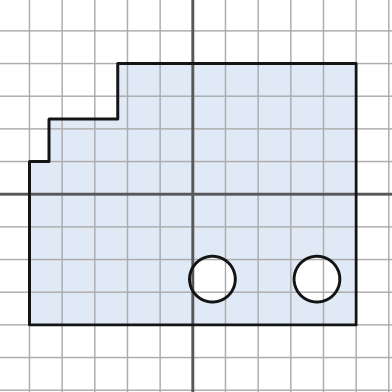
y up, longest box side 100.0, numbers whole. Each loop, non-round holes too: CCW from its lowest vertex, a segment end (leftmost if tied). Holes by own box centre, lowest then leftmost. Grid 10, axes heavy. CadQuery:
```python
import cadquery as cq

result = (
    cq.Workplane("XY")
    .moveTo(-50.0, -40.0)
    .lineTo(50.0, -40.0)
    .lineTo(50.0, 40.0)
    .lineTo(-23.0, 40.0)
    .lineTo(-23.0, 23.0)
    .lineTo(-44.0, 23.0)
    .lineTo(-44.0, 10.0)
    .lineTo(-50.0, 10.0)
    .close()
    .moveTo(6.0, -26.0)
    .circle(7.0)
    .moveTo(38.0, -26.0)
    .circle(7.0)
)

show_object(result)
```